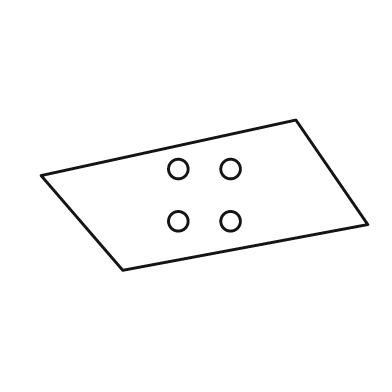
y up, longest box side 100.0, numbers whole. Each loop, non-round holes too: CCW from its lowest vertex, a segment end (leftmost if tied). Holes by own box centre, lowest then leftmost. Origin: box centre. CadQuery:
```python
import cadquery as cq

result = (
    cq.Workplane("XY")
    .moveTo(-25.0, -23.0)
    .lineTo(50.0, -9.0)
    .lineTo(28.0, 23.0)
    .lineTo(-50.0, 6.0)
    .close()
    .moveTo(-8.0, -8.0)
    .circle(3.0)
    .moveTo(8.0, -8.0)
    .circle(3.0)
    .moveTo(-8.0, 8.0)
    .circle(3.0)
    .moveTo(8.0, 8.0)
    .circle(3.0)
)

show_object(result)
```